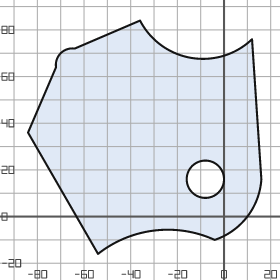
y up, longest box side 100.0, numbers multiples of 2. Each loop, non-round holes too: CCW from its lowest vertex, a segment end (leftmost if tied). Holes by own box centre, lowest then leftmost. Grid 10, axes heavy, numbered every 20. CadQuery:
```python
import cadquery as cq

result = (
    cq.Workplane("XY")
    .moveTo(-54.0, -16.0)
    .threePointArc((-30.0, -6.0), (-4.0, -10.0))
    .threePointArc((10.0, 0.0), (16.0, 16.0))
    .lineTo(12.0, 76.0)
    .threePointArc((-14.0, 68.0), (-36.0, 84.0))
    .lineTo(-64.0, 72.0)
    .threePointArc((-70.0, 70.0), (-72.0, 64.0))
    .lineTo(-84.0, 36.0)
    .close()
    .moveTo(-8.0, 16.0)
    .circle(8.0)
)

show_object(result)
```